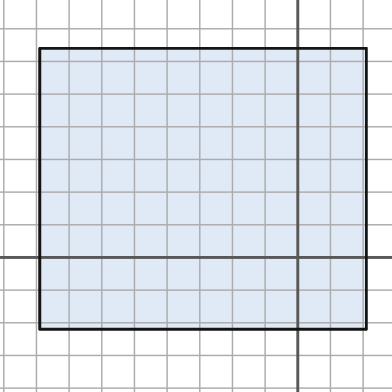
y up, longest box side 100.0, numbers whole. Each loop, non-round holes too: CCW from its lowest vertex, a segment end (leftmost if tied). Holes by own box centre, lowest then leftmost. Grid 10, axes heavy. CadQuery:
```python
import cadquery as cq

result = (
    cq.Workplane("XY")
    .moveTo(-79.0, -22.0)
    .lineTo(21.0, -22.0)
    .lineTo(21.0, 64.0)
    .lineTo(-79.0, 64.0)
    .close()
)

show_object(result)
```